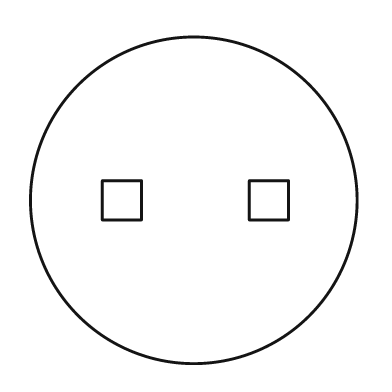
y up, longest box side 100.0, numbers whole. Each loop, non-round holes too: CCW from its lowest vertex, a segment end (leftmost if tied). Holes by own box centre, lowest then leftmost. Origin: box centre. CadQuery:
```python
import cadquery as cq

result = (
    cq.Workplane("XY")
    .moveTo(0.0, 0.0)
    .circle(50.0)
    .moveTo(-28.0, -6.0)
    .lineTo(-16.0, -6.0)
    .lineTo(-16.0, 6.0)
    .lineTo(-28.0, 6.0)
    .close()
    .moveTo(17.0, -6.0)
    .lineTo(29.0, -6.0)
    .lineTo(29.0, 6.0)
    .lineTo(17.0, 6.0)
    .close()
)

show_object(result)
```